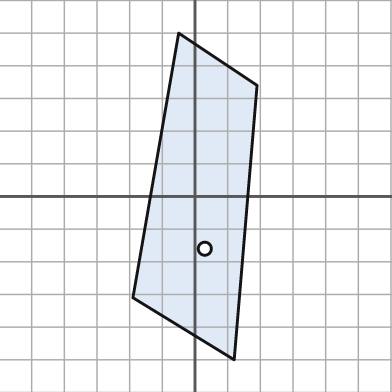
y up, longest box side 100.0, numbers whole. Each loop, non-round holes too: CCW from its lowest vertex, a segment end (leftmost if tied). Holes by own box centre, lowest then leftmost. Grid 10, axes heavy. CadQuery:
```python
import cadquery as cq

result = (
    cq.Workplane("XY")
    .moveTo(12.0, -50.0)
    .lineTo(19.0, 34.0)
    .lineTo(-5.0, 50.0)
    .lineTo(-19.0, -31.0)
    .close()
    .moveTo(3.0, -16.0)
    .circle(2.0)
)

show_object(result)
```